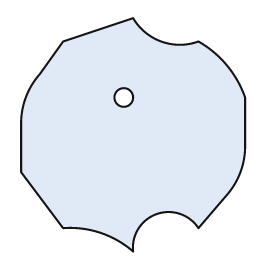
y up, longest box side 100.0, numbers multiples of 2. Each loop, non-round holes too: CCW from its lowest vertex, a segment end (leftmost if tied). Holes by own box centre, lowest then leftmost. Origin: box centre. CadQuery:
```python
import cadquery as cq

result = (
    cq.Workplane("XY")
    .moveTo(0.0, -50.0)
    .threePointArc((10.0, -34.0), (28.0, -40.0))
    .lineTo(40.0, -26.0)
    .threePointArc((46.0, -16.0), (48.0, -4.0))
    .lineTo(48.0, 16.0)
    .threePointArc((40.0, 30.0), (28.0, 40.0))
    .threePointArc((12.0, 40.0), (0.0, 50.0))
    .lineTo(-30.0, 40.0)
    .lineTo(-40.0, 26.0)
    .threePointArc((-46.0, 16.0), (-48.0, 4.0))
    .lineTo(-48.0, -16.0)
    .lineTo(-30.0, -40.0)
    .threePointArc((-14.0, -42.0), (0.0, -50.0))
    .close()
    .moveTo(-4.0, 16.0)
    .circle(4.0)
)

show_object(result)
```